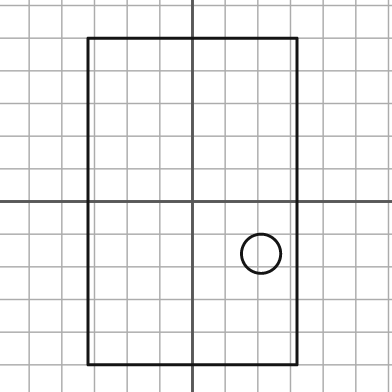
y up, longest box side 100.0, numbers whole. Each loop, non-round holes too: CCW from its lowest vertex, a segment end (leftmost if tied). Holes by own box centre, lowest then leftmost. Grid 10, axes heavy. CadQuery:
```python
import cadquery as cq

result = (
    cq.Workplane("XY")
    .moveTo(-32.0, -50.0)
    .lineTo(32.0, -50.0)
    .lineTo(32.0, 50.0)
    .lineTo(-32.0, 50.0)
    .close()
    .moveTo(21.0, -16.0)
    .circle(6.0)
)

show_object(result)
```